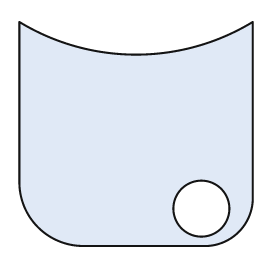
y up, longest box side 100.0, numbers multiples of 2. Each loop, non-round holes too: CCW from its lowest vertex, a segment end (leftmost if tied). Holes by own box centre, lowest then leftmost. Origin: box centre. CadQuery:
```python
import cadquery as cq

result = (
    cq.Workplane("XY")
    .moveTo(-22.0, -48.0)
    .lineTo(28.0, -48.0)
    .threePointArc((44.0, -42.0), (50.0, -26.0))
    .lineTo(50.0, 48.0)
    .threePointArc((0.0, 34.0), (-50.0, 48.0))
    .lineTo(-50.0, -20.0)
    .threePointArc((-42.0, -40.0), (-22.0, -48.0))
    .close()
    .moveTo(28.0, -32.0)
    .circle(12.0)
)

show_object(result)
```